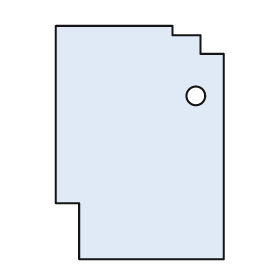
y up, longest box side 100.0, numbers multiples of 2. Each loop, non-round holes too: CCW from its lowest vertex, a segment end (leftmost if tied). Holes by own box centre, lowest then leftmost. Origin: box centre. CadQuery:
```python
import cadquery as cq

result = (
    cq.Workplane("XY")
    .moveTo(-26.0, -50.0)
    .lineTo(36.0, -50.0)
    .lineTo(36.0, 38.0)
    .lineTo(26.0, 38.0)
    .lineTo(26.0, 46.0)
    .lineTo(14.0, 46.0)
    .lineTo(14.0, 50.0)
    .lineTo(-36.0, 50.0)
    .lineTo(-36.0, -26.0)
    .lineTo(-26.0, -26.0)
    .close()
    .moveTo(24.0, 20.0)
    .circle(4.0)
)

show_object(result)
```